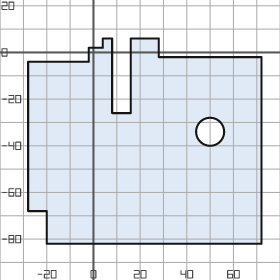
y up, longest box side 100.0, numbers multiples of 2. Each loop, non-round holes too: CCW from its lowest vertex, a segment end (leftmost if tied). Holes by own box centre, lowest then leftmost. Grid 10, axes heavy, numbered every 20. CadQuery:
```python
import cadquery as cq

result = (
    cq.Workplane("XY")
    .moveTo(-20.0, -82.0)
    .lineTo(72.0, -82.0)
    .lineTo(72.0, -2.0)
    .lineTo(28.0, -2.0)
    .lineTo(28.0, 6.0)
    .lineTo(16.0, 6.0)
    .lineTo(16.0, -26.0)
    .lineTo(8.0, -26.0)
    .lineTo(8.0, 6.0)
    .lineTo(4.0, 6.0)
    .lineTo(4.0, 2.0)
    .lineTo(-2.0, 2.0)
    .lineTo(-2.0, -4.0)
    .lineTo(-28.0, -4.0)
    .lineTo(-28.0, -68.0)
    .lineTo(-20.0, -68.0)
    .close()
    .moveTo(50.0, -34.0)
    .circle(6.0)
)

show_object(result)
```